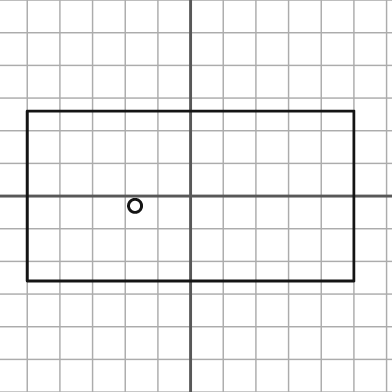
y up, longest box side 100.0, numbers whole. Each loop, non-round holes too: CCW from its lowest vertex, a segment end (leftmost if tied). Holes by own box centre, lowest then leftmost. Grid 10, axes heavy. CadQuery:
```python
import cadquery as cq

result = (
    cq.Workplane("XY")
    .moveTo(-50.0, -26.0)
    .lineTo(50.0, -26.0)
    .lineTo(50.0, 26.0)
    .lineTo(-50.0, 26.0)
    .close()
    .moveTo(-17.0, -3.0)
    .circle(2.0)
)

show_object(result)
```